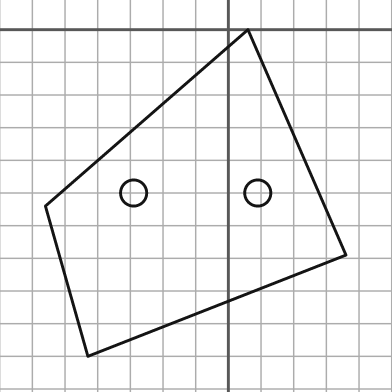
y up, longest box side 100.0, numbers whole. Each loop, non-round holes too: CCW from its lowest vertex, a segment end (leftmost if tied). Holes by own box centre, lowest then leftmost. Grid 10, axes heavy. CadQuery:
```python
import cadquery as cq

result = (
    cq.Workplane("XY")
    .moveTo(-43.0, -100.0)
    .lineTo(36.0, -69.0)
    .lineTo(6.0, 0.0)
    .lineTo(-56.0, -54.0)
    .close()
    .moveTo(-29.0, -50.0)
    .circle(4.0)
    .moveTo(9.0, -50.0)
    .circle(4.0)
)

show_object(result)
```